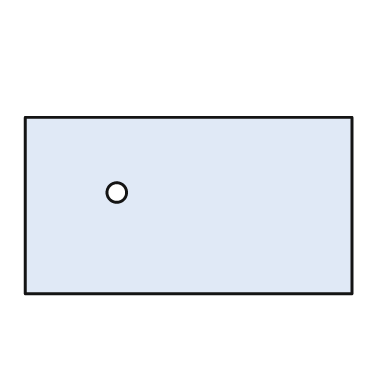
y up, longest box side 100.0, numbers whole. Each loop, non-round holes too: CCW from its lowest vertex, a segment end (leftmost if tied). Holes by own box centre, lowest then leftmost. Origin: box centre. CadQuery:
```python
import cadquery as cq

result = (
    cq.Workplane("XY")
    .moveTo(-50.0, -27.0)
    .lineTo(50.0, -27.0)
    .lineTo(50.0, 27.0)
    .lineTo(-50.0, 27.0)
    .close()
    .moveTo(-22.0, 4.0)
    .circle(3.0)
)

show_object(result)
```